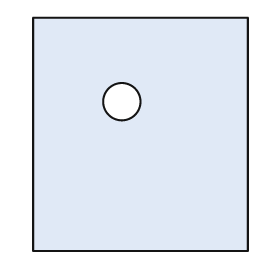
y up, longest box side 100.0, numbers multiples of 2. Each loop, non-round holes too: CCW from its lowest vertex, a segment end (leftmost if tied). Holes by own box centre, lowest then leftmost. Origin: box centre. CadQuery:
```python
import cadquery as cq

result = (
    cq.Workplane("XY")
    .moveTo(-46.0, -50.0)
    .lineTo(46.0, -50.0)
    .lineTo(46.0, 50.0)
    .lineTo(-46.0, 50.0)
    .close()
    .moveTo(-8.0, 14.0)
    .circle(8.0)
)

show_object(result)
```